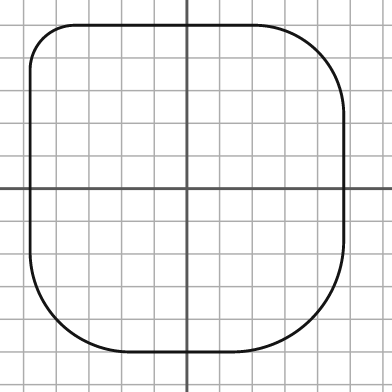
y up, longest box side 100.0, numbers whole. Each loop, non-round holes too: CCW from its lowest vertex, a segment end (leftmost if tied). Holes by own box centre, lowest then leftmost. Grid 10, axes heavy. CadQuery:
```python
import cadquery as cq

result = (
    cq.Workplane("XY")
    .moveTo(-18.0, -50.0)
    .lineTo(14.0, -50.0)
    .threePointArc((38.0, -40.0), (48.0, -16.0))
    .lineTo(48.0, 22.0)
    .threePointArc((40.0, 42.0), (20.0, 50.0))
    .lineTo(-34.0, 50.0)
    .threePointArc((-44.0, 46.0), (-48.0, 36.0))
    .lineTo(-48.0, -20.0)
    .threePointArc((-39.0, -41.0), (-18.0, -50.0))
    .close()
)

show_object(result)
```